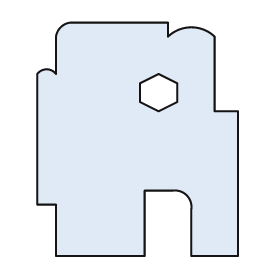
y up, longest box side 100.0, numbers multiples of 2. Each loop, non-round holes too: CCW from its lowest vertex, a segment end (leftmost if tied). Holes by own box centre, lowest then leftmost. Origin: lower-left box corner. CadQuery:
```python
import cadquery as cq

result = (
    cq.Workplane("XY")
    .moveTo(8.0, 0.0)
    .lineTo(46.0, 0.0)
    .lineTo(46.0, 28.0)
    .lineTo(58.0, 28.0)
    .threePointArc((64.0, 26.0), (66.0, 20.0))
    .lineTo(66.0, 0.0)
    .lineTo(86.0, 0.0)
    .lineTo(86.0, 62.0)
    .lineTo(76.0, 62.0)
    .lineTo(76.0, 94.0)
    .threePointArc((66.0, 98.0), (56.0, 94.0))
    .lineTo(56.0, 100.0)
    .lineTo(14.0, 100.0)
    .threePointArc((10.0, 98.0), (8.0, 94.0))
    .lineTo(8.0, 78.0)
    .threePointArc((4.0, 80.0), (0.0, 78.0))
    .lineTo(0.0, 22.0)
    .lineTo(8.0, 22.0)
    .close()
    .moveTo(52.0, 62.0)
    .lineTo(60.0, 66.0)
    .lineTo(60.0, 74.0)
    .lineTo(52.0, 78.0)
    .lineTo(44.0, 74.0)
    .lineTo(44.0, 66.0)
    .close()
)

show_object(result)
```